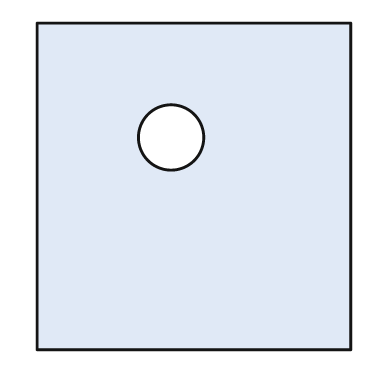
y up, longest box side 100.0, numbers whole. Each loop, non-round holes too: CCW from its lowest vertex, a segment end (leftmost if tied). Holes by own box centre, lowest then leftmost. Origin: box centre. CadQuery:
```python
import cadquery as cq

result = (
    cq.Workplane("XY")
    .moveTo(-48.0, -50.0)
    .lineTo(48.0, -50.0)
    .lineTo(48.0, 50.0)
    .lineTo(-48.0, 50.0)
    .close()
    .moveTo(-7.0, 15.0)
    .circle(10.0)
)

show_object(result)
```